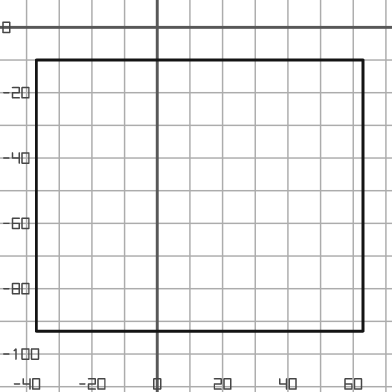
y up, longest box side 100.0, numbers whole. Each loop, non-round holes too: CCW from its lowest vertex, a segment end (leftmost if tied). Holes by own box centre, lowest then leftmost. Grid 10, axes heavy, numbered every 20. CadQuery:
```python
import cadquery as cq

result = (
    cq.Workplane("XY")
    .moveTo(-37.0, -93.0)
    .lineTo(63.0, -93.0)
    .lineTo(63.0, -10.0)
    .lineTo(-37.0, -10.0)
    .close()
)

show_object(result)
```